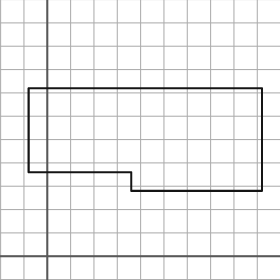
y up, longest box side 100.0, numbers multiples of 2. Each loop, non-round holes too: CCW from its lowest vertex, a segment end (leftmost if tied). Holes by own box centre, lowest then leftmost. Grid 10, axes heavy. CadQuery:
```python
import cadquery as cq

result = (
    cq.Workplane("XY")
    .moveTo(36.0, 28.0)
    .lineTo(92.0, 28.0)
    .lineTo(92.0, 72.0)
    .lineTo(-8.0, 72.0)
    .lineTo(-8.0, 36.0)
    .lineTo(36.0, 36.0)
    .close()
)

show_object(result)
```